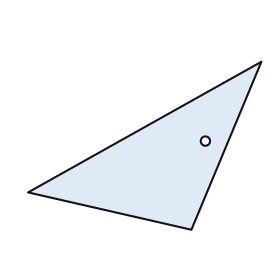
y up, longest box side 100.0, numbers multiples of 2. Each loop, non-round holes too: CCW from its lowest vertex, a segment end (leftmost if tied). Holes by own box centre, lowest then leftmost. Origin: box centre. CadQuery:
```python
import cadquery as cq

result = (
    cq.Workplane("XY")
    .moveTo(20.0, -36.0)
    .lineTo(50.0, 36.0)
    .lineTo(-50.0, -20.0)
    .close()
    .moveTo(26.0, 2.0)
    .circle(2.0)
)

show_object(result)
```